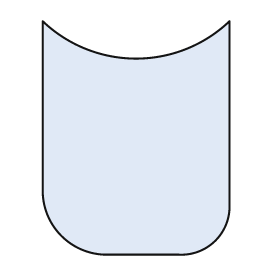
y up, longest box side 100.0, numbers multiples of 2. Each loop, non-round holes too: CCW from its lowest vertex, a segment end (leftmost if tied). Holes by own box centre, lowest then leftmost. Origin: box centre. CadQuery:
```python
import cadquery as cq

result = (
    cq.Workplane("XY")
    .moveTo(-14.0, -50.0)
    .lineTo(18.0, -50.0)
    .threePointArc((34.0, -44.0), (40.0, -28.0))
    .lineTo(40.0, 50.0)
    .threePointArc((0.0, 34.0), (-40.0, 50.0))
    .lineTo(-40.0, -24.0)
    .threePointArc((-32.0, -42.0), (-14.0, -50.0))
    .close()
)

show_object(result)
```